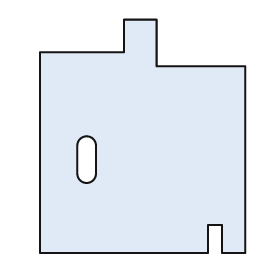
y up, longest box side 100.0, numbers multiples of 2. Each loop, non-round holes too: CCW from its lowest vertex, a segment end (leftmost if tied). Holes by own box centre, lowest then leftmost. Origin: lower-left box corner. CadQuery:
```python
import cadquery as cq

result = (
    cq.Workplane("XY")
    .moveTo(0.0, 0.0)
    .lineTo(72.0, 0.0)
    .lineTo(72.0, 12.0)
    .lineTo(78.0, 12.0)
    .lineTo(78.0, 0.0)
    .lineTo(88.0, 0.0)
    .lineTo(88.0, 80.0)
    .lineTo(50.0, 80.0)
    .lineTo(50.0, 100.0)
    .lineTo(36.0, 100.0)
    .lineTo(36.0, 86.0)
    .lineTo(0.0, 86.0)
    .close()
    .moveTo(16.0, 34.0)
    .threePointArc((20.0, 30.0), (24.0, 34.0))
    .lineTo(24.0, 46.0)
    .threePointArc((20.0, 50.0), (16.0, 46.0))
    .close()
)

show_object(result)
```